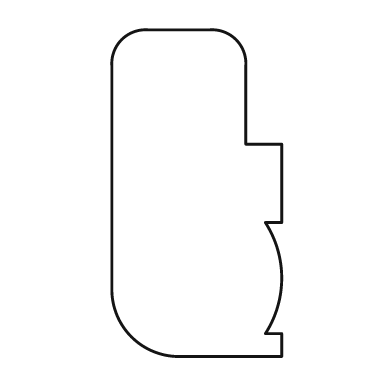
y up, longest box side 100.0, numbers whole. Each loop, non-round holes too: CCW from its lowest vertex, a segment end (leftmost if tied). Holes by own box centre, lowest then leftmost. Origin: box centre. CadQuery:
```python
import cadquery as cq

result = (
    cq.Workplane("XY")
    .moveTo(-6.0, -50.0)
    .lineTo(26.0, -50.0)
    .lineTo(26.0, -43.0)
    .lineTo(21.0, -43.0)
    .threePointArc((26.0, -26.0), (21.0, -9.0))
    .lineTo(26.0, -9.0)
    .lineTo(26.0, 15.0)
    .lineTo(15.0, 15.0)
    .lineTo(15.0, 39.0)
    .threePointArc((12.0, 47.0), (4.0, 50.0))
    .lineTo(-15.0, 50.0)
    .threePointArc((-23.0, 47.0), (-26.0, 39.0))
    .lineTo(-26.0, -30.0)
    .threePointArc((-20.0, -44.0), (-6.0, -50.0))
    .close()
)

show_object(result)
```